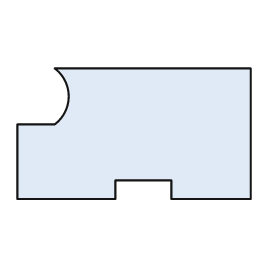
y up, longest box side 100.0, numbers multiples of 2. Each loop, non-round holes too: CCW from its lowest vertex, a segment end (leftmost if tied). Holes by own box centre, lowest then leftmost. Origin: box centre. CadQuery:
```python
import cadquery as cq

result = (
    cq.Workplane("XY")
    .moveTo(-50.0, -28.0)
    .lineTo(-8.0, -28.0)
    .lineTo(-8.0, -20.0)
    .lineTo(16.0, -20.0)
    .lineTo(16.0, -28.0)
    .lineTo(50.0, -28.0)
    .lineTo(50.0, 28.0)
    .lineTo(-34.0, 28.0)
    .threePointArc((-28.0, 16.0), (-34.0, 4.0))
    .lineTo(-50.0, 4.0)
    .close()
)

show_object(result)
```